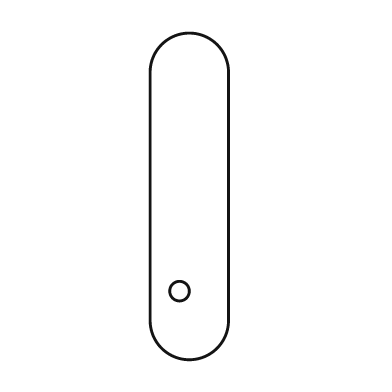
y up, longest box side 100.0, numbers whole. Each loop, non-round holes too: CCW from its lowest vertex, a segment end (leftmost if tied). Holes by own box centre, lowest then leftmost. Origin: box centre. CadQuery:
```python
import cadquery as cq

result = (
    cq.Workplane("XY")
    .moveTo(-12.0, -38.0)
    .threePointArc((0.0, -50.0), (12.0, -38.0))
    .lineTo(12.0, 38.0)
    .threePointArc((0.0, 50.0), (-12.0, 38.0))
    .close()
    .moveTo(-3.0, -29.0)
    .circle(3.0)
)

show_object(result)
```